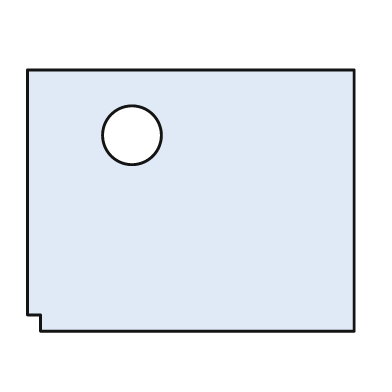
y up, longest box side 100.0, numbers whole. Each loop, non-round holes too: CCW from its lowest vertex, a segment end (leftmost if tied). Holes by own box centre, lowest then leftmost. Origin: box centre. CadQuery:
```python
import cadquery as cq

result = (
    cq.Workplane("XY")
    .moveTo(-46.0, -40.0)
    .lineTo(50.0, -40.0)
    .lineTo(50.0, 40.0)
    .lineTo(-50.0, 40.0)
    .lineTo(-50.0, -35.0)
    .lineTo(-46.0, -35.0)
    .close()
    .moveTo(-18.0, 20.0)
    .circle(9.0)
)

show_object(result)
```